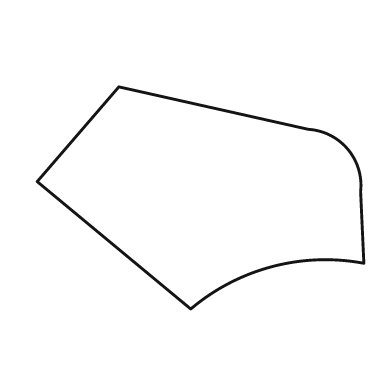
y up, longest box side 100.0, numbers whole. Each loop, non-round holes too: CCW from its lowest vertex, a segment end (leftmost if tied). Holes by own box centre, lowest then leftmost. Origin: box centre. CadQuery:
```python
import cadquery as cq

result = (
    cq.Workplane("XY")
    .moveTo(-3.0, -34.0)
    .threePointArc((22.0, -21.0), (50.0, -20.0))
    .lineTo(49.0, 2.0)
    .threePointArc((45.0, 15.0), (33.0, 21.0))
    .lineTo(-25.0, 34.0)
    .lineTo(-50.0, 5.0)
    .close()
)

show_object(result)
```